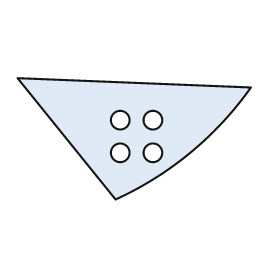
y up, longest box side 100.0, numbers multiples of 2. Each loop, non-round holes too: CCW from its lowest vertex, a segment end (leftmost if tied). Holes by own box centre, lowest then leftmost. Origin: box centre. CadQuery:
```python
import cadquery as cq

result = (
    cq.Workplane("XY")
    .moveTo(-8.0, -26.0)
    .threePointArc((24.0, -6.0), (50.0, 22.0))
    .lineTo(-50.0, 26.0)
    .close()
    .moveTo(-6.0, -6.0)
    .circle(4.0)
    .moveTo(8.0, -6.0)
    .circle(4.0)
    .moveTo(-6.0, 8.0)
    .circle(4.0)
    .moveTo(8.0, 8.0)
    .circle(4.0)
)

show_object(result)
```